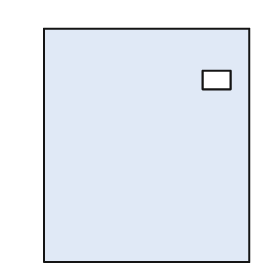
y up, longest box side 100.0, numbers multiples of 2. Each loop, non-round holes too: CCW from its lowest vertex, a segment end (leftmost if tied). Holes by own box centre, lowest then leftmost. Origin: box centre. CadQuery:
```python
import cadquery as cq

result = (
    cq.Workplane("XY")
    .moveTo(-44.0, -50.0)
    .lineTo(44.0, -50.0)
    .lineTo(44.0, 50.0)
    .lineTo(-44.0, 50.0)
    .close()
    .moveTo(24.0, 24.0)
    .lineTo(36.0, 24.0)
    .lineTo(36.0, 32.0)
    .lineTo(24.0, 32.0)
    .close()
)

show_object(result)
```